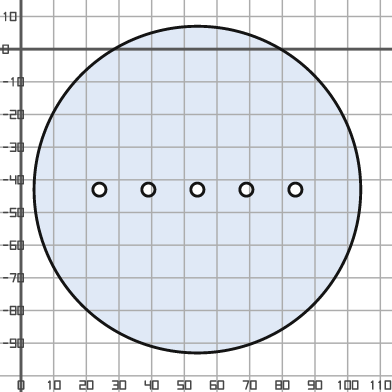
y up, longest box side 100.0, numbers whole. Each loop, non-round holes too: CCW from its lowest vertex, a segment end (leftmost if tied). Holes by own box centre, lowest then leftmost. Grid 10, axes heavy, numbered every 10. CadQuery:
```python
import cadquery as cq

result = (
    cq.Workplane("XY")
    .moveTo(54.0, -43.0)
    .circle(50.0)
    .moveTo(24.0, -43.0)
    .circle(2.0)
    .moveTo(39.0, -43.0)
    .circle(2.0)
    .moveTo(54.0, -43.0)
    .circle(2.0)
    .moveTo(69.0, -43.0)
    .circle(2.0)
    .moveTo(84.0, -43.0)
    .circle(2.0)
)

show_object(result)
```